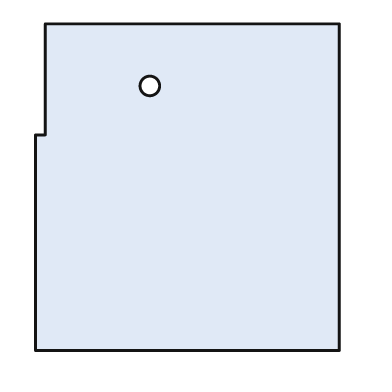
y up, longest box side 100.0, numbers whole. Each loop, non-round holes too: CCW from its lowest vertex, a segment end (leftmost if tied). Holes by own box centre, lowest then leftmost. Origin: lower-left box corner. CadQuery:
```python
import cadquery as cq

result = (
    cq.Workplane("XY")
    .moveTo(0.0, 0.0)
    .lineTo(93.0, 0.0)
    .lineTo(93.0, 100.0)
    .lineTo(3.0, 100.0)
    .lineTo(3.0, 66.0)
    .lineTo(0.0, 66.0)
    .close()
    .moveTo(35.0, 81.0)
    .circle(3.0)
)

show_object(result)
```